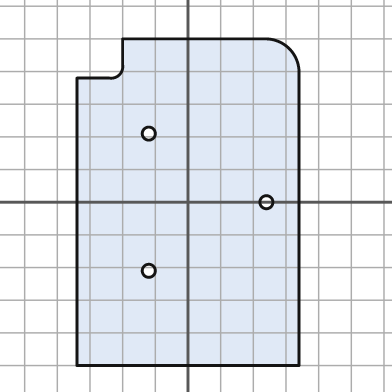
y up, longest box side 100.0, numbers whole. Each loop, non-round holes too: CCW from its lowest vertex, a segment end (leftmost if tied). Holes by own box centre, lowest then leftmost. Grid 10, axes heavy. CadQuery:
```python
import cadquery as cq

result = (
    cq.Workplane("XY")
    .moveTo(-34.0, -50.0)
    .lineTo(34.0, -50.0)
    .lineTo(34.0, 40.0)
    .threePointArc((31.0, 47.0), (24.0, 50.0))
    .lineTo(-20.0, 50.0)
    .lineTo(-20.0, 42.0)
    .threePointArc((-21.0, 39.0), (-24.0, 38.0))
    .lineTo(-34.0, 38.0)
    .close()
    .moveTo(-12.0, -21.0)
    .circle(2.0)
    .moveTo(24.0, 0.0)
    .circle(2.0)
    .moveTo(-12.0, 21.0)
    .circle(2.0)
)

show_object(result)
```